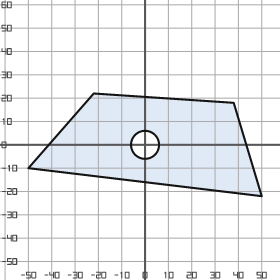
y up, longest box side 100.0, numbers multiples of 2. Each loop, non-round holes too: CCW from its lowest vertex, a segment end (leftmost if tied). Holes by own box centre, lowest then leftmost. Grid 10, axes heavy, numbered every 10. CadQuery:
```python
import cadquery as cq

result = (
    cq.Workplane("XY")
    .moveTo(50.0, -22.0)
    .lineTo(38.0, 18.0)
    .lineTo(-22.0, 22.0)
    .lineTo(-50.0, -10.0)
    .close()
    .moveTo(0.0, 0.0)
    .circle(6.0)
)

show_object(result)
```